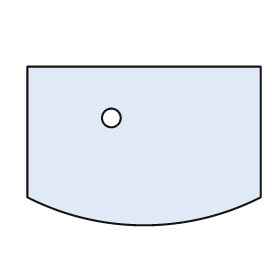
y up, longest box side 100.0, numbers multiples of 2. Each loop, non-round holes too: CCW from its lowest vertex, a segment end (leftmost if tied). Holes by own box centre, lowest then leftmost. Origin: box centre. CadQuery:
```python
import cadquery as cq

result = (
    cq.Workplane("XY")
    .moveTo(-50.0, -22.0)
    .threePointArc((0.0, -34.0), (50.0, -22.0))
    .lineTo(50.0, 34.0)
    .lineTo(-50.0, 34.0)
    .close()
    .moveTo(-14.0, 12.0)
    .circle(4.0)
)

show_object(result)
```